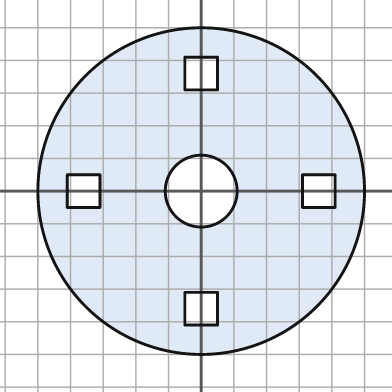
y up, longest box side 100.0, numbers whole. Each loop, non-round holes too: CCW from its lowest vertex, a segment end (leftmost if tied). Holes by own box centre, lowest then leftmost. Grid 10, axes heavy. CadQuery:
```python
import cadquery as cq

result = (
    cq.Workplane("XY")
    .moveTo(0.0, 0.0)
    .circle(50.0)
    .moveTo(-5.0, -41.0)
    .lineTo(5.0, -41.0)
    .lineTo(5.0, -31.0)
    .lineTo(-5.0, -31.0)
    .close()
    .moveTo(-41.0, -5.0)
    .lineTo(-31.0, -5.0)
    .lineTo(-31.0, 5.0)
    .lineTo(-41.0, 5.0)
    .close()
    .moveTo(0.0, 0.0)
    .circle(11.0)
    .moveTo(31.0, -5.0)
    .lineTo(41.0, -5.0)
    .lineTo(41.0, 5.0)
    .lineTo(31.0, 5.0)
    .close()
    .moveTo(-5.0, 31.0)
    .lineTo(5.0, 31.0)
    .lineTo(5.0, 41.0)
    .lineTo(-5.0, 41.0)
    .close()
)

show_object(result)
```